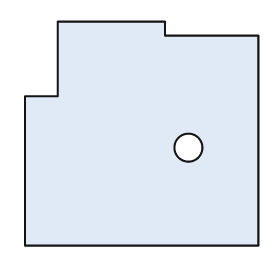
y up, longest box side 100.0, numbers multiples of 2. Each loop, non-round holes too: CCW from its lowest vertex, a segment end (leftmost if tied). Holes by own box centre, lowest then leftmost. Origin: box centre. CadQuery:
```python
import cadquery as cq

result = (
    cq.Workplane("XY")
    .moveTo(-50.0, -48.0)
    .lineTo(50.0, -48.0)
    .lineTo(50.0, 42.0)
    .lineTo(10.0, 42.0)
    .lineTo(10.0, 48.0)
    .lineTo(-36.0, 48.0)
    .lineTo(-36.0, 16.0)
    .lineTo(-50.0, 16.0)
    .close()
    .moveTo(20.0, -6.0)
    .circle(6.0)
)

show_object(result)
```